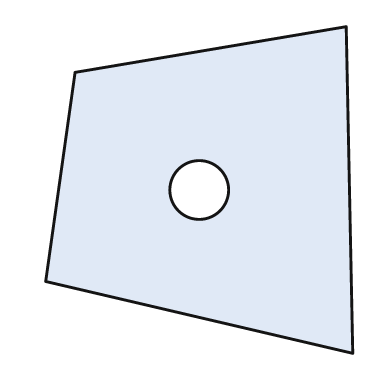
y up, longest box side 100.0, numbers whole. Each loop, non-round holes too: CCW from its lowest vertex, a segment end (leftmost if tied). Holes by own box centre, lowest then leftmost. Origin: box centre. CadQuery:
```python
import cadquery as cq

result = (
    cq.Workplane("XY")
    .moveTo(47.0, -50.0)
    .lineTo(45.0, 50.0)
    .lineTo(-38.0, 36.0)
    .lineTo(-47.0, -28.0)
    .close()
    .moveTo(0.0, 0.0)
    .circle(9.0)
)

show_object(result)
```